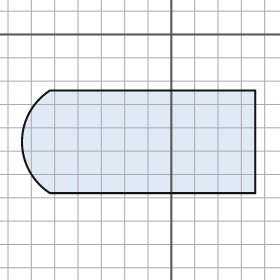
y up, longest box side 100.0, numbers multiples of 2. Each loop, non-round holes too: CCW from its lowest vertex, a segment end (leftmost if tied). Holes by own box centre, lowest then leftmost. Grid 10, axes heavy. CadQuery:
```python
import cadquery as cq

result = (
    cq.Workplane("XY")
    .moveTo(-52.0, -68.0)
    .lineTo(36.0, -68.0)
    .lineTo(36.0, -24.0)
    .lineTo(-52.0, -24.0)
    .threePointArc((-64.0, -46.0), (-52.0, -68.0))
    .close()
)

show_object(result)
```